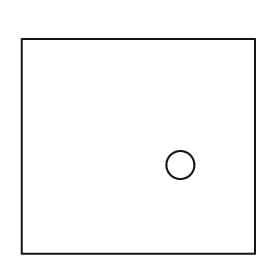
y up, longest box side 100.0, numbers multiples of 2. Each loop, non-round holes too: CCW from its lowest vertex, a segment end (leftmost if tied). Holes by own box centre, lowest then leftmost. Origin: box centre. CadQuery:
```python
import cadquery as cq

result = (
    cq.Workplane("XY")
    .moveTo(-50.0, -46.0)
    .lineTo(50.0, -46.0)
    .lineTo(50.0, 46.0)
    .lineTo(-50.0, 46.0)
    .close()
    .moveTo(18.0, -8.0)
    .circle(6.0)
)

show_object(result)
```